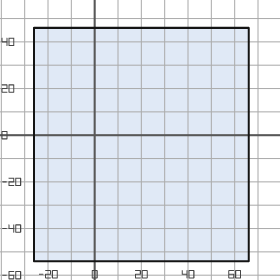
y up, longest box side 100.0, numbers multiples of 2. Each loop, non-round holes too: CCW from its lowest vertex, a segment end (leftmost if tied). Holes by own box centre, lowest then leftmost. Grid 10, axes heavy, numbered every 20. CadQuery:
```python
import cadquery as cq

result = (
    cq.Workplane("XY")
    .moveTo(-26.0, -54.0)
    .lineTo(66.0, -54.0)
    .lineTo(66.0, 46.0)
    .lineTo(-26.0, 46.0)
    .close()
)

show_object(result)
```